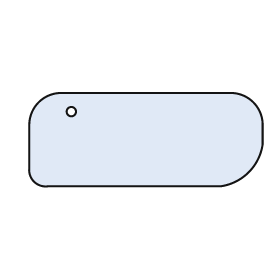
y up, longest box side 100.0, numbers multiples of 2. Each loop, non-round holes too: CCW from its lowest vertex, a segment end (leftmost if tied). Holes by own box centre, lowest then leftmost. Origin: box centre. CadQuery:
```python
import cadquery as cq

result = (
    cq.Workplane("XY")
    .moveTo(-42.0, -20.0)
    .lineTo(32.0, -20.0)
    .threePointArc((44.0, -14.0), (50.0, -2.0))
    .lineTo(50.0, 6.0)
    .threePointArc((46.0, 16.0), (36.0, 20.0))
    .lineTo(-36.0, 20.0)
    .threePointArc((-46.0, 16.0), (-50.0, 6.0))
    .lineTo(-50.0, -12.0)
    .threePointArc((-48.0, -18.0), (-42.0, -20.0))
    .close()
    .moveTo(-32.0, 12.0)
    .circle(2.0)
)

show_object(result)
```